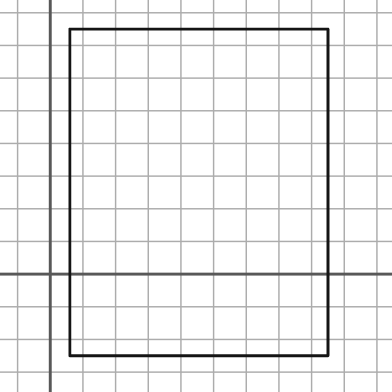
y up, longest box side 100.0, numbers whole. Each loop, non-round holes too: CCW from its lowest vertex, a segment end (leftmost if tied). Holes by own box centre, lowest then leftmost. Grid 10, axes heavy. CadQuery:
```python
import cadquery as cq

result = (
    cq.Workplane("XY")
    .moveTo(6.0, -25.0)
    .lineTo(85.0, -25.0)
    .lineTo(85.0, 75.0)
    .lineTo(6.0, 75.0)
    .close()
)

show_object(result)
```